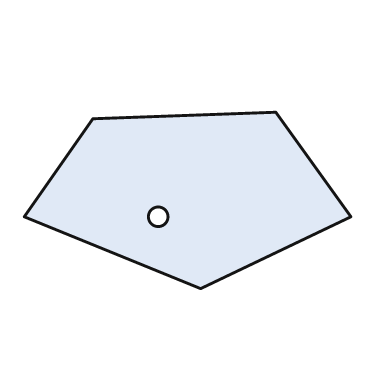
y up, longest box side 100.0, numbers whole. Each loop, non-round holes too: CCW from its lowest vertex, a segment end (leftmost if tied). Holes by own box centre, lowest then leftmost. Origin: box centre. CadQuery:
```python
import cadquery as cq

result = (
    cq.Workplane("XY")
    .moveTo(4.0, -27.0)
    .lineTo(50.0, -5.0)
    .lineTo(27.0, 27.0)
    .lineTo(-29.0, 25.0)
    .lineTo(-50.0, -5.0)
    .close()
    .moveTo(-9.0, -5.0)
    .circle(3.0)
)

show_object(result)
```